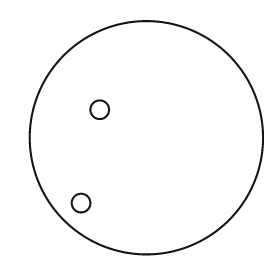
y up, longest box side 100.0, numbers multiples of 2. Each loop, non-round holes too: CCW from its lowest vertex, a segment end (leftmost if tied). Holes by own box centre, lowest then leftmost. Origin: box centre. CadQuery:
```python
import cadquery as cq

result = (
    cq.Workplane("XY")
    .moveTo(0.0, 0.0)
    .circle(50.0)
    .moveTo(-28.0, -28.0)
    .circle(4.0)
    .moveTo(-20.0, 12.0)
    .circle(4.0)
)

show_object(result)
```